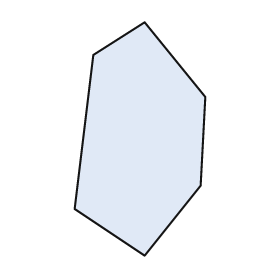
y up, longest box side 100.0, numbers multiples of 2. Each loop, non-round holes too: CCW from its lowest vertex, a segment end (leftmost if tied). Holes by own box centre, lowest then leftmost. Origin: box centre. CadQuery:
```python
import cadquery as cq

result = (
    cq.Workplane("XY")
    .moveTo(2.0, -50.0)
    .lineTo(26.0, -20.0)
    .lineTo(28.0, 18.0)
    .lineTo(2.0, 50.0)
    .lineTo(-20.0, 36.0)
    .lineTo(-28.0, -30.0)
    .close()
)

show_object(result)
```